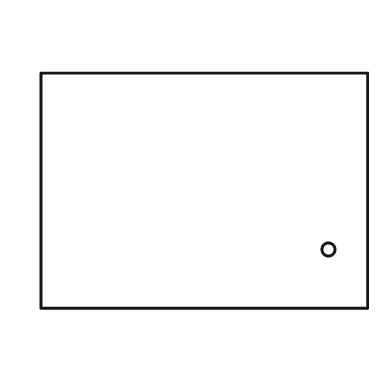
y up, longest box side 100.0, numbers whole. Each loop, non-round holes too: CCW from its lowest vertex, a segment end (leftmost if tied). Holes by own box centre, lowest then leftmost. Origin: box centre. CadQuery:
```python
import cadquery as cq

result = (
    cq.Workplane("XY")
    .moveTo(-50.0, -36.0)
    .lineTo(50.0, -36.0)
    .lineTo(50.0, 36.0)
    .lineTo(-50.0, 36.0)
    .close()
    .moveTo(38.0, -18.0)
    .circle(2.0)
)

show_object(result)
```